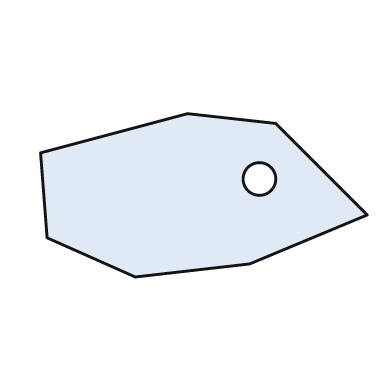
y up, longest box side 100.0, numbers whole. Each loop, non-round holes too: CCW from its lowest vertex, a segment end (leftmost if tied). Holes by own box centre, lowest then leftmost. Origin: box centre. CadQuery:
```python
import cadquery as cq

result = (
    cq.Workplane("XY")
    .moveTo(-21.0, -25.0)
    .lineTo(14.0, -21.0)
    .lineTo(50.0, -6.0)
    .lineTo(22.0, 22.0)
    .lineTo(-5.0, 25.0)
    .lineTo(-50.0, 13.0)
    .lineTo(-48.0, -13.0)
    .close()
    .moveTo(17.0, 5.0)
    .circle(5.0)
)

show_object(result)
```